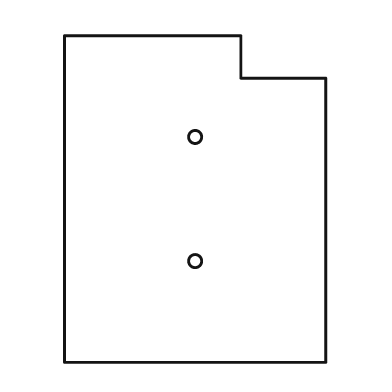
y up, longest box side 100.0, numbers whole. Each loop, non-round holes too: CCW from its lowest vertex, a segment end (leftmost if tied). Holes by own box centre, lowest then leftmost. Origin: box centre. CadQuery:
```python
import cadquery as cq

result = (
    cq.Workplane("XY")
    .moveTo(-40.0, -50.0)
    .lineTo(40.0, -50.0)
    .lineTo(40.0, 37.0)
    .lineTo(14.0, 37.0)
    .lineTo(14.0, 50.0)
    .lineTo(-40.0, 50.0)
    .close()
    .moveTo(0.0, -19.0)
    .circle(2.0)
    .moveTo(0.0, 19.0)
    .circle(2.0)
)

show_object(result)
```